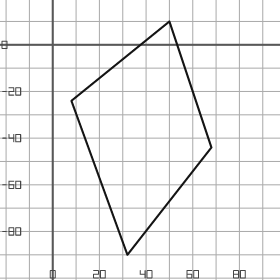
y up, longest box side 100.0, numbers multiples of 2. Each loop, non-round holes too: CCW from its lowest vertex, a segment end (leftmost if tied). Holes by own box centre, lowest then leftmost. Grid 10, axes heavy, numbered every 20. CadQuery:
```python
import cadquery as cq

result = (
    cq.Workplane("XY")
    .moveTo(32.0, -90.0)
    .lineTo(68.0, -44.0)
    .lineTo(50.0, 10.0)
    .lineTo(8.0, -24.0)
    .close()
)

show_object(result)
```